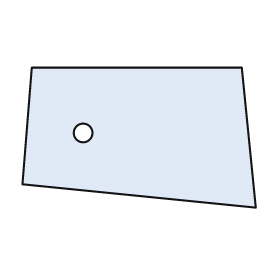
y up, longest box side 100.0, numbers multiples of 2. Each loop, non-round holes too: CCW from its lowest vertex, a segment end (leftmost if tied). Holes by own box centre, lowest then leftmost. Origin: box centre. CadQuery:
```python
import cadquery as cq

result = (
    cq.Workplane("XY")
    .moveTo(50.0, -30.0)
    .lineTo(44.0, 30.0)
    .lineTo(-46.0, 30.0)
    .lineTo(-50.0, -20.0)
    .close()
    .moveTo(-24.0, 2.0)
    .circle(4.0)
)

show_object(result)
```